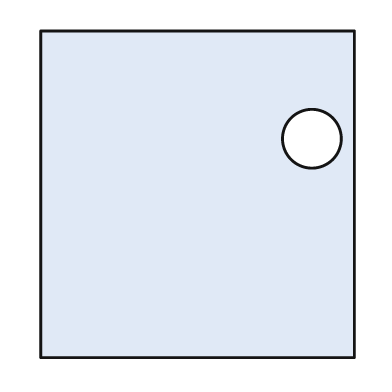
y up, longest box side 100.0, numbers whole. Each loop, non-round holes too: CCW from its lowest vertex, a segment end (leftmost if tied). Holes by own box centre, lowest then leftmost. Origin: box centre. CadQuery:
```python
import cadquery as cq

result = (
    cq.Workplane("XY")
    .moveTo(-48.0, -50.0)
    .lineTo(48.0, -50.0)
    .lineTo(48.0, 50.0)
    .lineTo(-48.0, 50.0)
    .close()
    .moveTo(35.0, 17.0)
    .circle(9.0)
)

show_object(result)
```